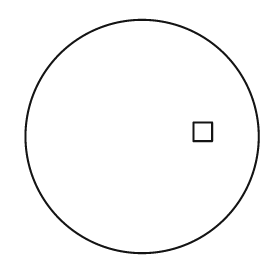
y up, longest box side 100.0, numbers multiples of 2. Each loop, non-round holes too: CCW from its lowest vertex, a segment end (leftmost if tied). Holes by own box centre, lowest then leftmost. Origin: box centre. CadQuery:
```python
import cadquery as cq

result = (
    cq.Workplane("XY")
    .moveTo(0.0, 0.0)
    .circle(50.0)
    .moveTo(22.0, -2.0)
    .lineTo(30.0, -2.0)
    .lineTo(30.0, 6.0)
    .lineTo(22.0, 6.0)
    .close()
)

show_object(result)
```